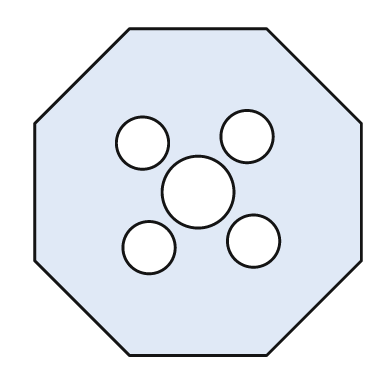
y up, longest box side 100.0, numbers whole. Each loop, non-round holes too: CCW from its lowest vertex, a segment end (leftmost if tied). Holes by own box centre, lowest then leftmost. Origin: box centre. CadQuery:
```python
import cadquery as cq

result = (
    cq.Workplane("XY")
    .moveTo(-21.0, -50.0)
    .lineTo(21.0, -50.0)
    .lineTo(50.0, -21.0)
    .lineTo(50.0, 21.0)
    .lineTo(21.0, 50.0)
    .lineTo(-21.0, 50.0)
    .lineTo(-50.0, 21.0)
    .lineTo(-50.0, -21.0)
    .close()
    .moveTo(-15.0, -17.0)
    .circle(8.0)
    .moveTo(17.0, -15.0)
    .circle(8.0)
    .moveTo(0.0, 0.0)
    .circle(11.0)
    .moveTo(-17.0, 15.0)
    .circle(8.0)
    .moveTo(15.0, 17.0)
    .circle(8.0)
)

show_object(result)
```